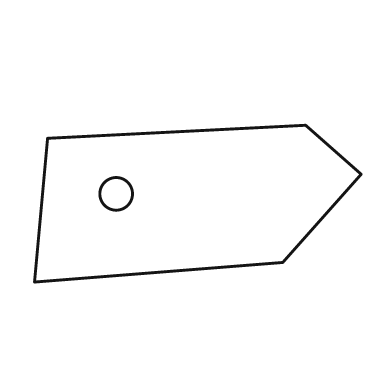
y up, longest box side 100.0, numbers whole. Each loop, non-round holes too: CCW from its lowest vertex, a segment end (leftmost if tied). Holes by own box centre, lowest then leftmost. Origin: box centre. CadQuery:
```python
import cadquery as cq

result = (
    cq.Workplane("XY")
    .moveTo(-50.0, -24.0)
    .lineTo(26.0, -18.0)
    .lineTo(50.0, 9.0)
    .lineTo(33.0, 24.0)
    .lineTo(-46.0, 20.0)
    .close()
    .moveTo(-25.0, 3.0)
    .circle(5.0)
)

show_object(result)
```